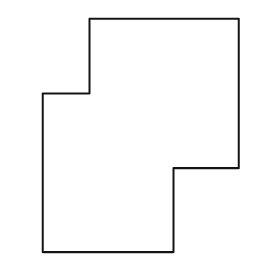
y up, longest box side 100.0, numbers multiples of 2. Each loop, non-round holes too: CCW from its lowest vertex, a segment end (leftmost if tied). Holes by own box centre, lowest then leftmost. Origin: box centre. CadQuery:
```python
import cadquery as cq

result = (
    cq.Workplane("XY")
    .moveTo(-42.0, -50.0)
    .lineTo(14.0, -50.0)
    .lineTo(14.0, -14.0)
    .lineTo(42.0, -14.0)
    .lineTo(42.0, 50.0)
    .lineTo(-22.0, 50.0)
    .lineTo(-22.0, 18.0)
    .lineTo(-42.0, 18.0)
    .close()
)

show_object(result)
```